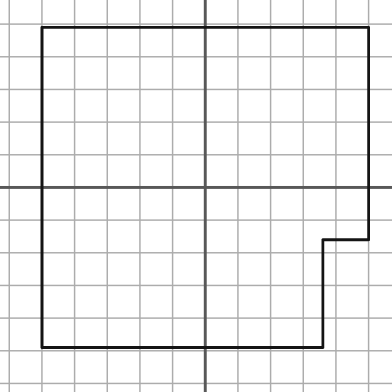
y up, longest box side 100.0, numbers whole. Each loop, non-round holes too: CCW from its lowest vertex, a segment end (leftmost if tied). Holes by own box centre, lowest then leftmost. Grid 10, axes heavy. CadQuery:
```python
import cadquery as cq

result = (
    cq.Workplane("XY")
    .moveTo(-50.0, -49.0)
    .lineTo(36.0, -49.0)
    .lineTo(36.0, -16.0)
    .lineTo(50.0, -16.0)
    .lineTo(50.0, 49.0)
    .lineTo(-50.0, 49.0)
    .close()
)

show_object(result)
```